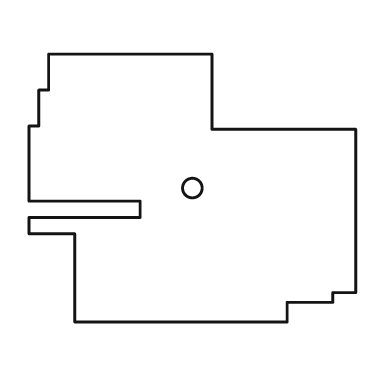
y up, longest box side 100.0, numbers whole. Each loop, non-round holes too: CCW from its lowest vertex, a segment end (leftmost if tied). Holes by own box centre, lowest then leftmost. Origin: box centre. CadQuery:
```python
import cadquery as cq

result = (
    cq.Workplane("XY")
    .moveTo(-36.0, -41.0)
    .lineTo(29.0, -41.0)
    .lineTo(29.0, -35.0)
    .lineTo(43.0, -35.0)
    .lineTo(43.0, -32.0)
    .lineTo(50.0, -32.0)
    .lineTo(50.0, 18.0)
    .lineTo(6.0, 18.0)
    .lineTo(6.0, 41.0)
    .lineTo(-44.0, 41.0)
    .lineTo(-44.0, 30.0)
    .lineTo(-47.0, 30.0)
    .lineTo(-47.0, 19.0)
    .lineTo(-50.0, 19.0)
    .lineTo(-50.0, -4.0)
    .lineTo(-16.0, -4.0)
    .lineTo(-16.0, -9.0)
    .lineTo(-50.0, -9.0)
    .lineTo(-50.0, -14.0)
    .lineTo(-36.0, -14.0)
    .close()
    .moveTo(0.0, 0.0)
    .circle(3.0)
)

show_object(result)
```